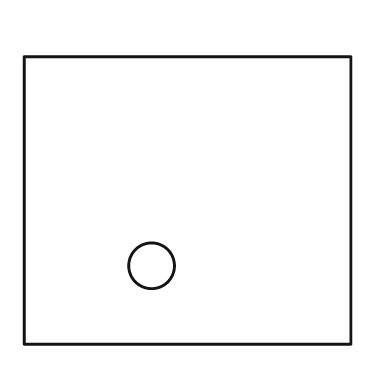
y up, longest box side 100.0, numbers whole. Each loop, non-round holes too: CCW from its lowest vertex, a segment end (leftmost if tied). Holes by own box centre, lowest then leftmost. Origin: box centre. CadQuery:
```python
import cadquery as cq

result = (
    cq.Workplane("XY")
    .moveTo(-50.0, -44.0)
    .lineTo(50.0, -44.0)
    .lineTo(50.0, 44.0)
    .lineTo(-50.0, 44.0)
    .close()
    .moveTo(-11.0, -20.0)
    .circle(7.0)
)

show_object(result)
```